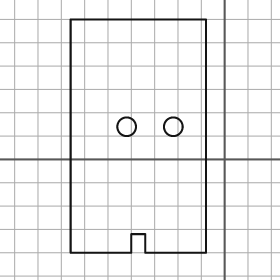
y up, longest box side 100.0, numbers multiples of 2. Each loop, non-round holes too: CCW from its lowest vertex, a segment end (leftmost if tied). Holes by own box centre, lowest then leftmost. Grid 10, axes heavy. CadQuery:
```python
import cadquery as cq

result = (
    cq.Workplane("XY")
    .moveTo(-66.0, -40.0)
    .lineTo(-40.0, -40.0)
    .lineTo(-40.0, -32.0)
    .lineTo(-34.0, -32.0)
    .lineTo(-34.0, -40.0)
    .lineTo(-8.0, -40.0)
    .lineTo(-8.0, 60.0)
    .lineTo(-66.0, 60.0)
    .close()
    .moveTo(-42.0, 14.0)
    .circle(4.0)
    .moveTo(-22.0, 14.0)
    .circle(4.0)
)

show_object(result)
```